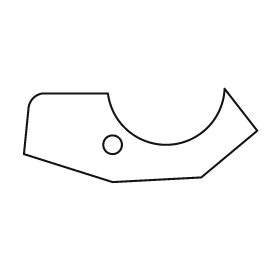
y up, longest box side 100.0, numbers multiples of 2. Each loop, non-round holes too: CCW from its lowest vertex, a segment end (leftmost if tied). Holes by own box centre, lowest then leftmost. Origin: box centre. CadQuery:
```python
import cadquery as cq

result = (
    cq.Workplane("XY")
    .moveTo(-12.0, -20.0)
    .lineTo(26.0, -18.0)
    .lineTo(50.0, 2.0)
    .lineTo(36.0, 20.0)
    .threePointArc((12.0, -4.0), (-14.0, 18.0))
    .lineTo(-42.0, 18.0)
    .threePointArc((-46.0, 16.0), (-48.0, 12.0))
    .lineTo(-50.0, -8.0)
    .close()
    .moveTo(-12.0, -4.0)
    .circle(4.0)
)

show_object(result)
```